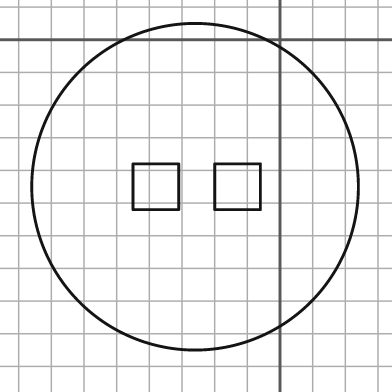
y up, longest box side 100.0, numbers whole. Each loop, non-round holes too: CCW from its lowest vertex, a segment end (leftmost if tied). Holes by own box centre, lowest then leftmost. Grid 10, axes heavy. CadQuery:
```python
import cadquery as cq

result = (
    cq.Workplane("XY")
    .moveTo(-26.0, -45.0)
    .circle(50.0)
    .moveTo(-45.0, -52.0)
    .lineTo(-31.0, -52.0)
    .lineTo(-31.0, -38.0)
    .lineTo(-45.0, -38.0)
    .close()
    .moveTo(-20.0, -52.0)
    .lineTo(-6.0, -52.0)
    .lineTo(-6.0, -38.0)
    .lineTo(-20.0, -38.0)
    .close()
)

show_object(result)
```